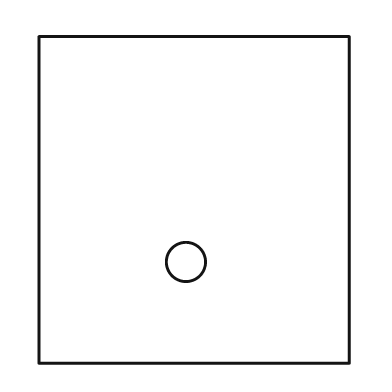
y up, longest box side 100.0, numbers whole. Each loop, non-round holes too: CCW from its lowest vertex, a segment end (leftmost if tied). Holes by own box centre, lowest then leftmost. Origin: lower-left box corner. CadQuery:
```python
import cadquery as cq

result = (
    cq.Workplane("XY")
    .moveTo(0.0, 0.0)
    .lineTo(95.0, 0.0)
    .lineTo(95.0, 100.0)
    .lineTo(0.0, 100.0)
    .close()
    .moveTo(45.0, 31.0)
    .circle(6.0)
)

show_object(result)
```